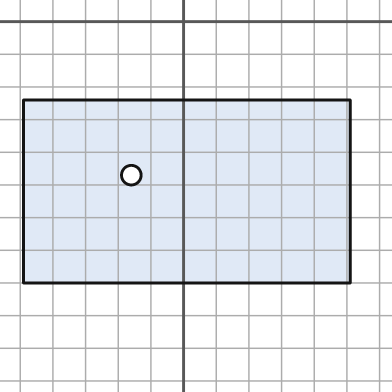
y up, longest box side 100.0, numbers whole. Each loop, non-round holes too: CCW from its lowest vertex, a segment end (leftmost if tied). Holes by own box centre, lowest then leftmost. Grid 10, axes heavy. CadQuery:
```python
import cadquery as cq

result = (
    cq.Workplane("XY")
    .moveTo(-49.0, -80.0)
    .lineTo(51.0, -80.0)
    .lineTo(51.0, -24.0)
    .lineTo(-49.0, -24.0)
    .close()
    .moveTo(-16.0, -47.0)
    .circle(3.0)
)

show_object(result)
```